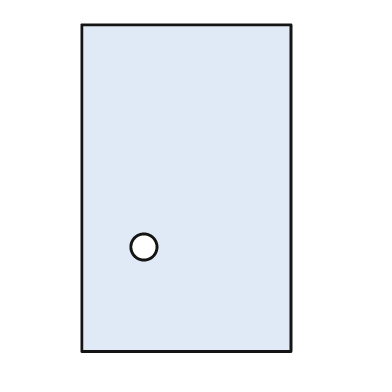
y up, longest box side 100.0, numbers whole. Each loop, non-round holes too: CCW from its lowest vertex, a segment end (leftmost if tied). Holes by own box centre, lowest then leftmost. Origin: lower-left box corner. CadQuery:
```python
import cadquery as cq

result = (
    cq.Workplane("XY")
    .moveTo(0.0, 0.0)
    .lineTo(64.0, 0.0)
    .lineTo(64.0, 100.0)
    .lineTo(0.0, 100.0)
    .close()
    .moveTo(19.0, 32.0)
    .circle(4.0)
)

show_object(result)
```